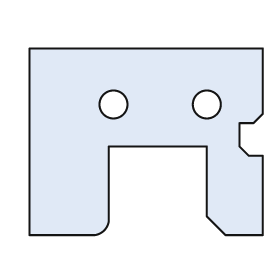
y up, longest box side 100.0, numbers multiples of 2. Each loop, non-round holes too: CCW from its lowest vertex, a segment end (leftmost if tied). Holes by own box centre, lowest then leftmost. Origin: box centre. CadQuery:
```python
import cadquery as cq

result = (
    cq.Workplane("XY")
    .moveTo(-50.0, -40.0)
    .lineTo(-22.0, -40.0)
    .threePointArc((-18.0, -38.0), (-16.0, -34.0))
    .lineTo(-16.0, -2.0)
    .lineTo(26.0, -2.0)
    .lineTo(26.0, -32.0)
    .lineTo(34.0, -40.0)
    .lineTo(50.0, -40.0)
    .lineTo(50.0, -6.0)
    .lineTo(44.0, -6.0)
    .lineTo(40.0, -2.0)
    .lineTo(40.0, 8.0)
    .lineTo(46.0, 8.0)
    .lineTo(50.0, 12.0)
    .lineTo(50.0, 40.0)
    .lineTo(-50.0, 40.0)
    .close()
    .moveTo(-14.0, 16.0)
    .circle(6.0)
    .moveTo(26.0, 16.0)
    .circle(6.0)
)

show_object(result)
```